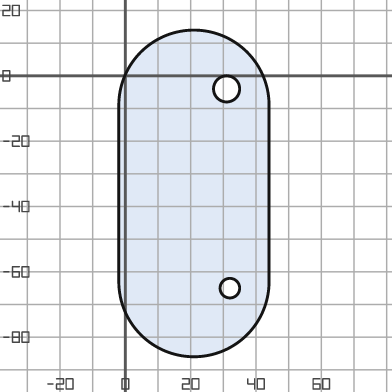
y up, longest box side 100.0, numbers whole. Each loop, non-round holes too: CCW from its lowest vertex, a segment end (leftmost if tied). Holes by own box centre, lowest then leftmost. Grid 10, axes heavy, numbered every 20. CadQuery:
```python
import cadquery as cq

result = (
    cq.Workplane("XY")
    .moveTo(-2.0, -63.0)
    .threePointArc((21.0, -86.0), (44.0, -63.0))
    .lineTo(44.0, -9.0)
    .threePointArc((21.0, 14.0), (-2.0, -9.0))
    .close()
    .moveTo(32.0, -65.0)
    .circle(3.0)
    .moveTo(31.0, -4.0)
    .circle(4.0)
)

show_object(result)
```